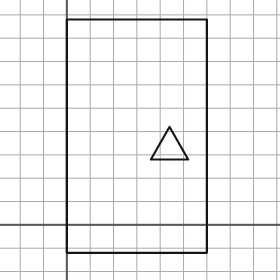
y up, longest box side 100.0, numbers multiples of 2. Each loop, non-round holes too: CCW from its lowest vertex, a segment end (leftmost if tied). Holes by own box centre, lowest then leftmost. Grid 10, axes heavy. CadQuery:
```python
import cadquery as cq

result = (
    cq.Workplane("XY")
    .moveTo(0.0, -12.0)
    .lineTo(60.0, -12.0)
    .lineTo(60.0, 88.0)
    .lineTo(0.0, 88.0)
    .close()
    .moveTo(36.0, 28.0)
    .lineTo(52.0, 28.0)
    .lineTo(44.0, 42.0)
    .close()
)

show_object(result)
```